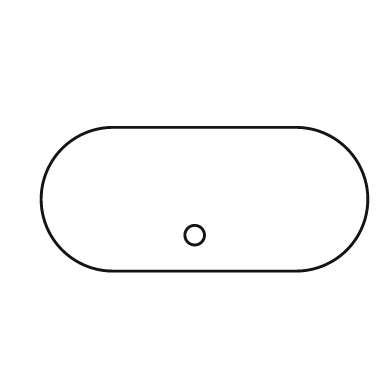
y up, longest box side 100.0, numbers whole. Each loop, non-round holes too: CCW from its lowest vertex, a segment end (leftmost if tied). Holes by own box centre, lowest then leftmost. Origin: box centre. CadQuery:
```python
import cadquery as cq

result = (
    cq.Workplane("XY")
    .moveTo(-28.0, -22.0)
    .lineTo(28.0, -22.0)
    .threePointArc((50.0, 0.0), (28.0, 22.0))
    .lineTo(-28.0, 22.0)
    .threePointArc((-50.0, 0.0), (-28.0, -22.0))
    .close()
    .moveTo(-3.0, -11.0)
    .circle(3.0)
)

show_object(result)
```